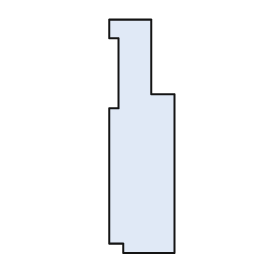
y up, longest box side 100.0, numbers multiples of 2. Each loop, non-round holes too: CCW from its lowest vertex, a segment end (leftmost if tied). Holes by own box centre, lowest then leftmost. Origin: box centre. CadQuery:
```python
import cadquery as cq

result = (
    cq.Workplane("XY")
    .moveTo(-8.0, -50.0)
    .lineTo(14.0, -50.0)
    .lineTo(14.0, 18.0)
    .lineTo(4.0, 18.0)
    .lineTo(4.0, 50.0)
    .lineTo(-14.0, 50.0)
    .lineTo(-14.0, 42.0)
    .lineTo(-10.0, 42.0)
    .lineTo(-10.0, 12.0)
    .lineTo(-14.0, 12.0)
    .lineTo(-14.0, -46.0)
    .lineTo(-8.0, -46.0)
    .close()
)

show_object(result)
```